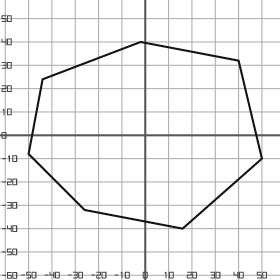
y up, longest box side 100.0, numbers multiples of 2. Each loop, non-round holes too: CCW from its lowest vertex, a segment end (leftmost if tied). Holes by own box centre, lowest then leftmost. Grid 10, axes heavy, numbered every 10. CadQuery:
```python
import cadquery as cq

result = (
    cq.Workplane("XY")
    .moveTo(16.0, -40.0)
    .lineTo(50.0, -10.0)
    .lineTo(40.0, 32.0)
    .lineTo(-2.0, 40.0)
    .lineTo(-44.0, 24.0)
    .lineTo(-50.0, -8.0)
    .lineTo(-26.0, -32.0)
    .close()
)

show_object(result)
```